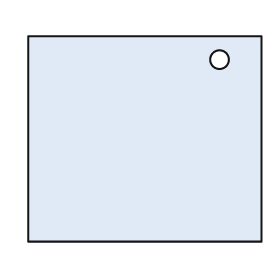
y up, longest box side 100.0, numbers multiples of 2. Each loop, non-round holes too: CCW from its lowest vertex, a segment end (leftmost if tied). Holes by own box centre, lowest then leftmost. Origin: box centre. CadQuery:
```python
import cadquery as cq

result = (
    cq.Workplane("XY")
    .moveTo(-50.0, -44.0)
    .lineTo(50.0, -44.0)
    .lineTo(50.0, 44.0)
    .lineTo(-50.0, 44.0)
    .close()
    .moveTo(32.0, 34.0)
    .circle(4.0)
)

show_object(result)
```